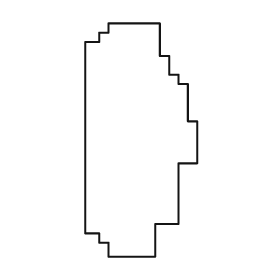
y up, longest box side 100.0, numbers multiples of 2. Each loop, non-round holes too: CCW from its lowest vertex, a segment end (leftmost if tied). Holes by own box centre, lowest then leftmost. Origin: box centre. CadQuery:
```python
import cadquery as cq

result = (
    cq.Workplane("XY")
    .moveTo(-14.0, -50.0)
    .lineTo(6.0, -50.0)
    .lineTo(6.0, -36.0)
    .lineTo(16.0, -36.0)
    .lineTo(16.0, -10.0)
    .lineTo(24.0, -10.0)
    .lineTo(24.0, 8.0)
    .lineTo(20.0, 8.0)
    .lineTo(20.0, 24.0)
    .lineTo(16.0, 24.0)
    .lineTo(16.0, 28.0)
    .lineTo(12.0, 28.0)
    .lineTo(12.0, 36.0)
    .lineTo(8.0, 36.0)
    .lineTo(8.0, 50.0)
    .lineTo(-14.0, 50.0)
    .lineTo(-14.0, 46.0)
    .lineTo(-18.0, 46.0)
    .lineTo(-18.0, 42.0)
    .lineTo(-24.0, 42.0)
    .lineTo(-24.0, -40.0)
    .lineTo(-18.0, -40.0)
    .lineTo(-18.0, -44.0)
    .lineTo(-14.0, -44.0)
    .close()
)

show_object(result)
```